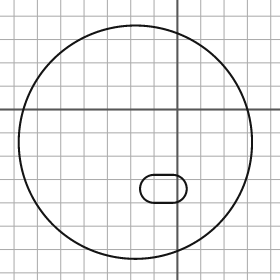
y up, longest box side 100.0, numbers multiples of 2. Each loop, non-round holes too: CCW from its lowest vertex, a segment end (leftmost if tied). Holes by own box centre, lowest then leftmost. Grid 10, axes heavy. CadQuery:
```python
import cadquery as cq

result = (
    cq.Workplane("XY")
    .moveTo(-18.0, -14.0)
    .circle(50.0)
    .moveTo(-10.0, -40.0)
    .lineTo(-2.0, -40.0)
    .threePointArc((4.0, -34.0), (-2.0, -28.0))
    .lineTo(-10.0, -28.0)
    .threePointArc((-16.0, -34.0), (-10.0, -40.0))
    .close()
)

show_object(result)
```